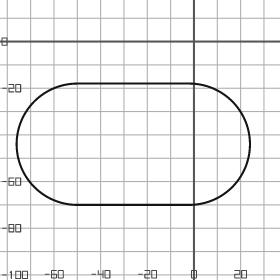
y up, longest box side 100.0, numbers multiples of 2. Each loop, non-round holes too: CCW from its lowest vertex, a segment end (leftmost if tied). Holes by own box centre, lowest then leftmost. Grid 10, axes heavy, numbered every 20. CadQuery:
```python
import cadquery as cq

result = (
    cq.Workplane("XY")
    .moveTo(-50.0, -70.0)
    .lineTo(-2.0, -70.0)
    .threePointArc((24.0, -44.0), (-2.0, -18.0))
    .lineTo(-50.0, -18.0)
    .threePointArc((-76.0, -44.0), (-50.0, -70.0))
    .close()
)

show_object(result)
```